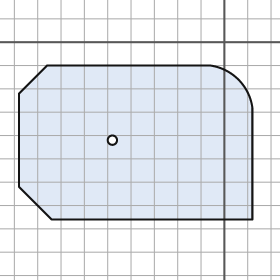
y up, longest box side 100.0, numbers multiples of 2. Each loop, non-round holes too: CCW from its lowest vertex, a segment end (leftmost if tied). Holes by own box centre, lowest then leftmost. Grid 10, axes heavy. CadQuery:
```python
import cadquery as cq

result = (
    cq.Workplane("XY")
    .moveTo(-74.0, -76.0)
    .lineTo(12.0, -76.0)
    .lineTo(12.0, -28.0)
    .threePointArc((6.0, -16.0), (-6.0, -10.0))
    .lineTo(-76.0, -10.0)
    .lineTo(-88.0, -22.0)
    .lineTo(-88.0, -62.0)
    .close()
    .moveTo(-48.0, -42.0)
    .circle(2.0)
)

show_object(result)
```